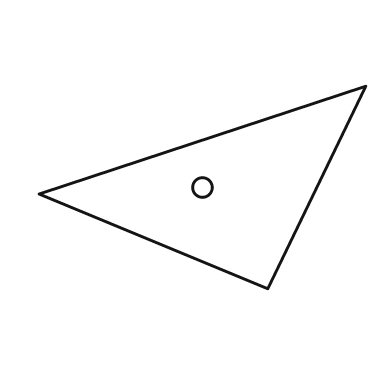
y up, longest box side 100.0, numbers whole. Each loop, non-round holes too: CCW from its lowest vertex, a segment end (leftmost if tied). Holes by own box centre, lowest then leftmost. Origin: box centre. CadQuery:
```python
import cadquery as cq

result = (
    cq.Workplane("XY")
    .moveTo(20.0, -31.0)
    .lineTo(50.0, 31.0)
    .lineTo(-50.0, -2.0)
    .close()
    .moveTo(0.0, 0.0)
    .circle(3.0)
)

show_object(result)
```